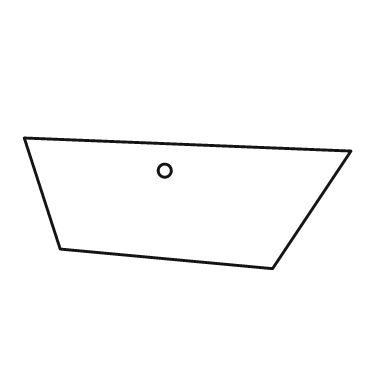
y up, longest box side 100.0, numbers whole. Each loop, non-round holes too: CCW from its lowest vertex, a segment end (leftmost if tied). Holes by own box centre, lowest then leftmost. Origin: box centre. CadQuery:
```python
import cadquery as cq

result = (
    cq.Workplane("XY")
    .moveTo(26.0, -20.0)
    .lineTo(50.0, 16.0)
    .lineTo(-50.0, 20.0)
    .lineTo(-39.0, -14.0)
    .close()
    .moveTo(-7.0, 10.0)
    .circle(2.0)
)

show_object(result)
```